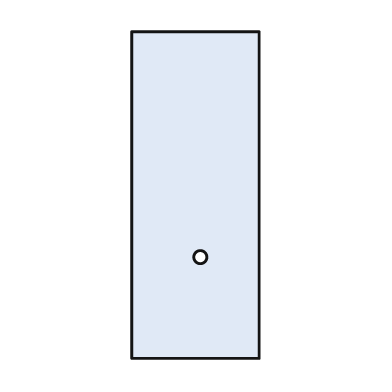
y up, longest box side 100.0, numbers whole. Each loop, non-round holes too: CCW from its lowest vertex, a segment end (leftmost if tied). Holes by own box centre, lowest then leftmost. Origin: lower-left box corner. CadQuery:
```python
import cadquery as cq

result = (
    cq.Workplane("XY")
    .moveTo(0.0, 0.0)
    .lineTo(39.0, 0.0)
    .lineTo(39.0, 100.0)
    .lineTo(0.0, 100.0)
    .close()
    .moveTo(21.0, 31.0)
    .circle(2.0)
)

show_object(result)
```